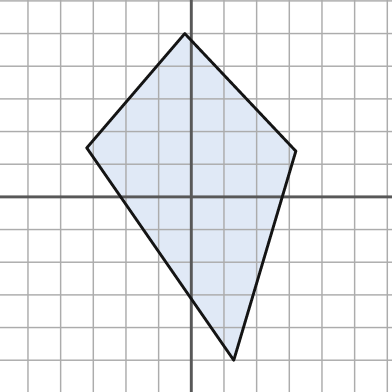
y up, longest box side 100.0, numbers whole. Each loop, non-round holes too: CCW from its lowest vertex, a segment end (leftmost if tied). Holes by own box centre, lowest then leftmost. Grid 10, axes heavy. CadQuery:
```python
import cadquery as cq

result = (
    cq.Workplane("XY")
    .moveTo(13.0, -50.0)
    .lineTo(32.0, 14.0)
    .lineTo(-2.0, 50.0)
    .lineTo(-32.0, 15.0)
    .close()
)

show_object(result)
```